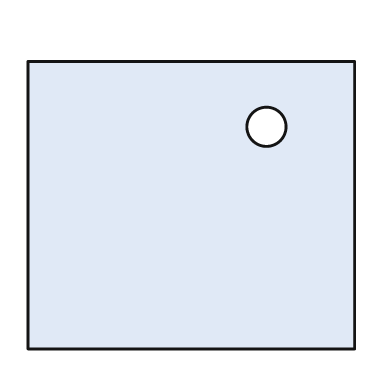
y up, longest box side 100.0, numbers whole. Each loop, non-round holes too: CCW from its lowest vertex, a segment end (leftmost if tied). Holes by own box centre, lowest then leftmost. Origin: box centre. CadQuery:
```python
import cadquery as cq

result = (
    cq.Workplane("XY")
    .moveTo(-50.0, -44.0)
    .lineTo(50.0, -44.0)
    .lineTo(50.0, 44.0)
    .lineTo(-50.0, 44.0)
    .close()
    .moveTo(23.0, 24.0)
    .circle(6.0)
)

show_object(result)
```